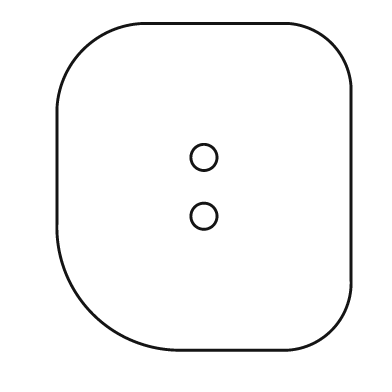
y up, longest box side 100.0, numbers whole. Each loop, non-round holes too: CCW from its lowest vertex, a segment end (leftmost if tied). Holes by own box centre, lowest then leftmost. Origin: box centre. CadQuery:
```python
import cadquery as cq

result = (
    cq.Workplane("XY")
    .moveTo(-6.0, -50.0)
    .lineTo(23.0, -50.0)
    .threePointArc((39.0, -44.0), (45.0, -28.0))
    .lineTo(45.0, 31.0)
    .threePointArc((39.0, 44.0), (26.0, 50.0))
    .lineTo(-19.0, 50.0)
    .threePointArc((-37.0, 42.0), (-45.0, 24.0))
    .lineTo(-45.0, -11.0)
    .threePointArc((-34.0, -39.0), (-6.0, -50.0))
    .close()
    .moveTo(0.0, -9.0)
    .circle(4.0)
    .moveTo(0.0, 9.0)
    .circle(4.0)
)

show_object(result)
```